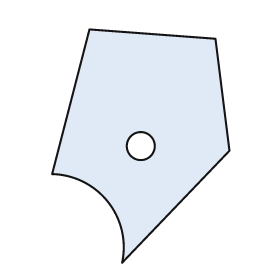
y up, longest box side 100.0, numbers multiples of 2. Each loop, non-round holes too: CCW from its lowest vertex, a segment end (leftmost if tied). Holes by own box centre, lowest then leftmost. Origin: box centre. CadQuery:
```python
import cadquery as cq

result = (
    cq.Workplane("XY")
    .moveTo(-8.0, -50.0)
    .lineTo(38.0, -2.0)
    .lineTo(32.0, 46.0)
    .lineTo(-22.0, 50.0)
    .lineTo(-38.0, -12.0)
    .threePointArc((-14.0, -24.0), (-8.0, -50.0))
    .close()
    .moveTo(0.0, 0.0)
    .circle(6.0)
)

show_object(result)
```